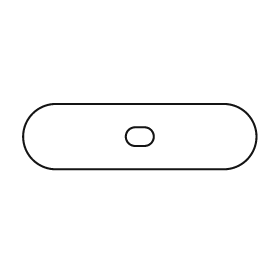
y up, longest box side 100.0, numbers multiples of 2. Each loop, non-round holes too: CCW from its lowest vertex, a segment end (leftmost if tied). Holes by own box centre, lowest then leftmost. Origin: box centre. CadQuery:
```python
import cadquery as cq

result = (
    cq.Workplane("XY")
    .moveTo(-36.0, -14.0)
    .lineTo(36.0, -14.0)
    .threePointArc((50.0, 0.0), (36.0, 14.0))
    .lineTo(-36.0, 14.0)
    .threePointArc((-50.0, 0.0), (-36.0, -14.0))
    .close()
    .moveTo(-2.0, -4.0)
    .lineTo(2.0, -4.0)
    .threePointArc((6.0, 0.0), (2.0, 4.0))
    .lineTo(-2.0, 4.0)
    .threePointArc((-6.0, 0.0), (-2.0, -4.0))
    .close()
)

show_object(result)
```